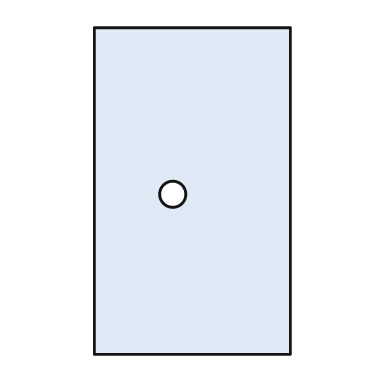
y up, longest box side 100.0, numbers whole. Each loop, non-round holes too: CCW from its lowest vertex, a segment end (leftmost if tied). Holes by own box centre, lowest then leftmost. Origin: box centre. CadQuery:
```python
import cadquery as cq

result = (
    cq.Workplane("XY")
    .moveTo(-30.0, -50.0)
    .lineTo(30.0, -50.0)
    .lineTo(30.0, 50.0)
    .lineTo(-30.0, 50.0)
    .close()
    .moveTo(-6.0, -1.0)
    .circle(4.0)
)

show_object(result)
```